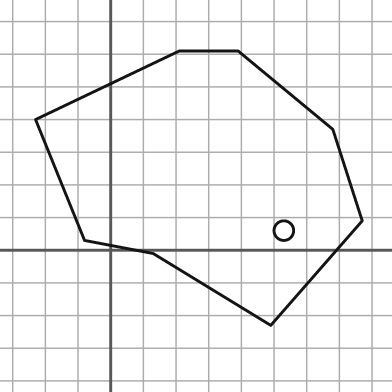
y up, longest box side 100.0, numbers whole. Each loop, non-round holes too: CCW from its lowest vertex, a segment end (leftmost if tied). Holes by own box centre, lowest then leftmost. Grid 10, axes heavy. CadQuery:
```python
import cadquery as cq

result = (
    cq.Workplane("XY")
    .moveTo(49.0, -23.0)
    .lineTo(77.0, 9.0)
    .lineTo(68.0, 37.0)
    .lineTo(39.0, 61.0)
    .lineTo(21.0, 61.0)
    .lineTo(-23.0, 40.0)
    .lineTo(-8.0, 3.0)
    .lineTo(13.0, -1.0)
    .close()
    .moveTo(53.0, 6.0)
    .circle(3.0)
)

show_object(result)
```